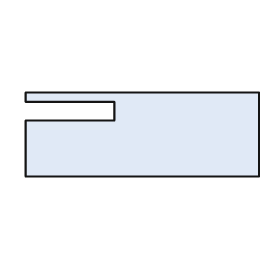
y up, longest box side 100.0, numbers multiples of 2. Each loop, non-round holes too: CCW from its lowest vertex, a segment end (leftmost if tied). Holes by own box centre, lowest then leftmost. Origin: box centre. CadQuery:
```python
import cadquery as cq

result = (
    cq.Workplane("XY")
    .moveTo(-50.0, -18.0)
    .lineTo(50.0, -18.0)
    .lineTo(50.0, 18.0)
    .lineTo(-50.0, 18.0)
    .lineTo(-50.0, 14.0)
    .lineTo(-12.0, 14.0)
    .lineTo(-12.0, 6.0)
    .lineTo(-50.0, 6.0)
    .close()
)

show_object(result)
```